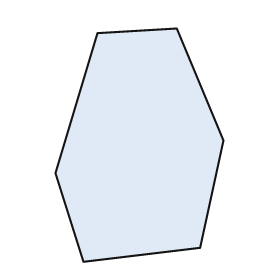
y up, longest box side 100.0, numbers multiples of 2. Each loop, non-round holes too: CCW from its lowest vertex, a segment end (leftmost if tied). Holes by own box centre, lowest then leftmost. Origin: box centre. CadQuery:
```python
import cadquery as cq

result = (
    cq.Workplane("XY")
    .moveTo(-24.0, -50.0)
    .lineTo(26.0, -44.0)
    .lineTo(36.0, 2.0)
    .lineTo(16.0, 50.0)
    .lineTo(-18.0, 48.0)
    .lineTo(-36.0, -12.0)
    .close()
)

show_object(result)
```